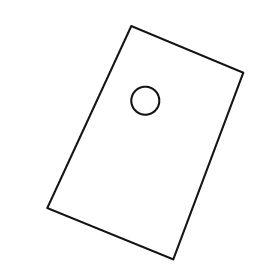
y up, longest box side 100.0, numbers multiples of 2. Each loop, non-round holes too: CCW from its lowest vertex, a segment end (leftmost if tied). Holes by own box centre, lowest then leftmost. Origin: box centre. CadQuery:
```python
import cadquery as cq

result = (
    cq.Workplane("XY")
    .moveTo(12.0, -50.0)
    .lineTo(42.0, 30.0)
    .lineTo(-6.0, 50.0)
    .lineTo(-42.0, -28.0)
    .close()
    .moveTo(0.0, 18.0)
    .circle(6.0)
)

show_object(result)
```